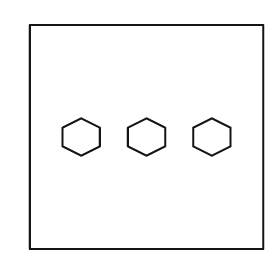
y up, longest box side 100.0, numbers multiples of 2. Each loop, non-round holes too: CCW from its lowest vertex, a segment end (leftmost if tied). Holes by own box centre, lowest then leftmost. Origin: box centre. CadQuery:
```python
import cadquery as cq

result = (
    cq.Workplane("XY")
    .moveTo(-50.0, -48.0)
    .lineTo(50.0, -48.0)
    .lineTo(50.0, 48.0)
    .lineTo(-50.0, 48.0)
    .close()
    .moveTo(-28.0, -8.0)
    .lineTo(-20.0, -4.0)
    .lineTo(-20.0, 4.0)
    .lineTo(-28.0, 8.0)
    .lineTo(-36.0, 4.0)
    .lineTo(-36.0, -4.0)
    .close()
    .moveTo(0.0, -8.0)
    .lineTo(8.0, -4.0)
    .lineTo(8.0, 4.0)
    .lineTo(0.0, 8.0)
    .lineTo(-8.0, 4.0)
    .lineTo(-8.0, -4.0)
    .close()
    .moveTo(28.0, -8.0)
    .lineTo(36.0, -4.0)
    .lineTo(36.0, 4.0)
    .lineTo(28.0, 8.0)
    .lineTo(20.0, 4.0)
    .lineTo(20.0, -4.0)
    .close()
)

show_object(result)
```